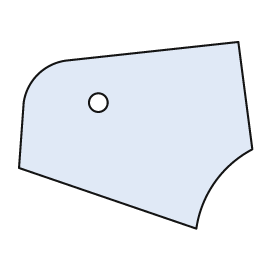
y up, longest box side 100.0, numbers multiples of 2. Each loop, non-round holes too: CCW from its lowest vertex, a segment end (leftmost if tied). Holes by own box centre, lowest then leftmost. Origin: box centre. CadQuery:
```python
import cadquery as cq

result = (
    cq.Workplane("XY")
    .moveTo(26.0, -40.0)
    .threePointArc((34.0, -20.0), (50.0, -6.0))
    .lineTo(44.0, 40.0)
    .lineTo(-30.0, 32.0)
    .threePointArc((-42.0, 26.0), (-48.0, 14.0))
    .lineTo(-50.0, -14.0)
    .close()
    .moveTo(-16.0, 14.0)
    .circle(4.0)
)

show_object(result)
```